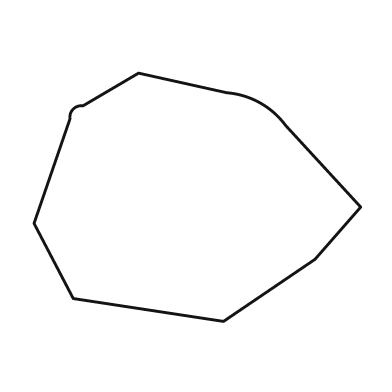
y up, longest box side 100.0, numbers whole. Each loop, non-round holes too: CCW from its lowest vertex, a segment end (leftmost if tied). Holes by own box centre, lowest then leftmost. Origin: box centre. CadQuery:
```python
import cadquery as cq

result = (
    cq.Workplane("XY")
    .moveTo(8.0, -38.0)
    .lineTo(36.0, -19.0)
    .lineTo(50.0, -3.0)
    .lineTo(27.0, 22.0)
    .threePointArc((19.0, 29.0), (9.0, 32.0))
    .lineTo(-18.0, 38.0)
    .lineTo(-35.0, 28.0)
    .threePointArc((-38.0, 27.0), (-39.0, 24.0))
    .lineTo(-50.0, -8.0)
    .lineTo(-38.0, -31.0)
    .close()
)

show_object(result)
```